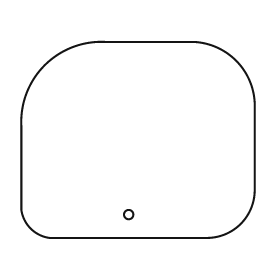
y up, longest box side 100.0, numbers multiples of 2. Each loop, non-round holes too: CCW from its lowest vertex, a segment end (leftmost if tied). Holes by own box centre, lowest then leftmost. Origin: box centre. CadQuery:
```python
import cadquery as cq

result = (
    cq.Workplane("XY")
    .moveTo(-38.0, -42.0)
    .lineTo(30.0, -42.0)
    .threePointArc((44.0, -36.0), (50.0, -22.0))
    .lineTo(50.0, 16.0)
    .threePointArc((42.0, 34.0), (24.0, 42.0))
    .lineTo(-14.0, 42.0)
    .threePointArc((-40.0, 32.0), (-50.0, 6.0))
    .lineTo(-50.0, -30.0)
    .threePointArc((-46.0, -38.0), (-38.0, -42.0))
    .close()
    .moveTo(-4.0, -32.0)
    .circle(2.0)
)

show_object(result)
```